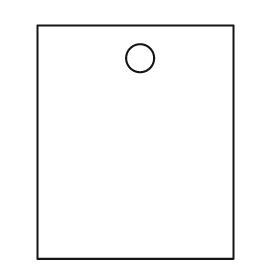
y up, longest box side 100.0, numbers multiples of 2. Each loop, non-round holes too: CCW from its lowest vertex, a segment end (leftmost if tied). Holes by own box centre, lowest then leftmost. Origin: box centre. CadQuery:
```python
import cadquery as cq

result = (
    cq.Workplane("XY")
    .moveTo(-42.0, -50.0)
    .lineTo(42.0, -50.0)
    .lineTo(42.0, 50.0)
    .lineTo(-42.0, 50.0)
    .close()
    .moveTo(2.0, 36.0)
    .circle(6.0)
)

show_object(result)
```